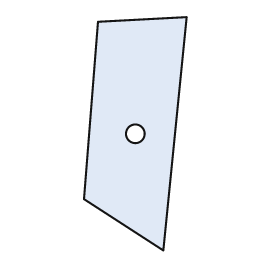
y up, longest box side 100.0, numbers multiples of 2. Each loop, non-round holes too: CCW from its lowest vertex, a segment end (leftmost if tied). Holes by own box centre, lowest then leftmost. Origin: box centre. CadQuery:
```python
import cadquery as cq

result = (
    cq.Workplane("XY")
    .moveTo(12.0, -50.0)
    .lineTo(22.0, 50.0)
    .lineTo(-16.0, 48.0)
    .lineTo(-22.0, -28.0)
    .close()
    .moveTo(0.0, 0.0)
    .circle(4.0)
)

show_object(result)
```